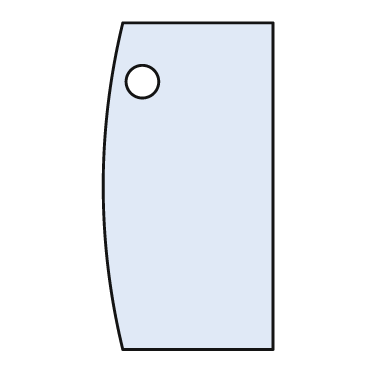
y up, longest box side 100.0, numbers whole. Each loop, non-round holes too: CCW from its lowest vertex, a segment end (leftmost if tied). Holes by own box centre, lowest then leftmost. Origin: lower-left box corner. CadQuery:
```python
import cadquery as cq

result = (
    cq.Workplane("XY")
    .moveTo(6.0, 0.0)
    .lineTo(52.0, 0.0)
    .lineTo(52.0, 100.0)
    .lineTo(6.0, 100.0)
    .threePointArc((0.0, 50.0), (6.0, 0.0))
    .close()
    .moveTo(12.0, 82.0)
    .circle(5.0)
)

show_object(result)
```